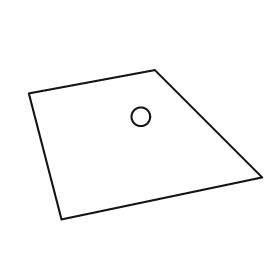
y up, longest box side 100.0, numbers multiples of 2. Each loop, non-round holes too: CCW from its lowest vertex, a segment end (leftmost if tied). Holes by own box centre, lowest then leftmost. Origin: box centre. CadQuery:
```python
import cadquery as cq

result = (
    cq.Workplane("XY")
    .moveTo(-36.0, -32.0)
    .lineTo(50.0, -14.0)
    .lineTo(4.0, 32.0)
    .lineTo(-50.0, 22.0)
    .close()
    .moveTo(-2.0, 12.0)
    .circle(4.0)
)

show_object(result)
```